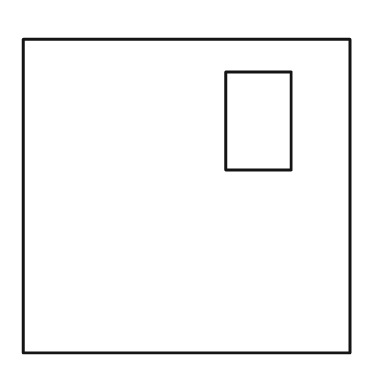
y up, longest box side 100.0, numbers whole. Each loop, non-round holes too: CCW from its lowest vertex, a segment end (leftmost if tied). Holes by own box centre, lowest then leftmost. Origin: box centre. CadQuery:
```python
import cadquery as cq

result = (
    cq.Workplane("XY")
    .moveTo(-50.0, -48.0)
    .lineTo(50.0, -48.0)
    .lineTo(50.0, 48.0)
    .lineTo(-50.0, 48.0)
    .close()
    .moveTo(12.0, 8.0)
    .lineTo(32.0, 8.0)
    .lineTo(32.0, 38.0)
    .lineTo(12.0, 38.0)
    .close()
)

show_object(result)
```